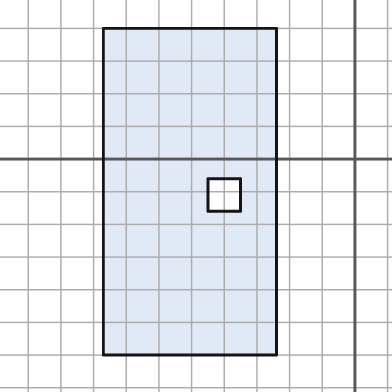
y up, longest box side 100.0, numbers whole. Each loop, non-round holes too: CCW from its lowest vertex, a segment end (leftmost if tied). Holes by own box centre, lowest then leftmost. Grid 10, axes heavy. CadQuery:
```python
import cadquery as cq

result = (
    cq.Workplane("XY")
    .moveTo(-77.0, -60.0)
    .lineTo(-24.0, -60.0)
    .lineTo(-24.0, 40.0)
    .lineTo(-77.0, 40.0)
    .close()
    .moveTo(-45.0, -16.0)
    .lineTo(-35.0, -16.0)
    .lineTo(-35.0, -6.0)
    .lineTo(-45.0, -6.0)
    .close()
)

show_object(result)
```